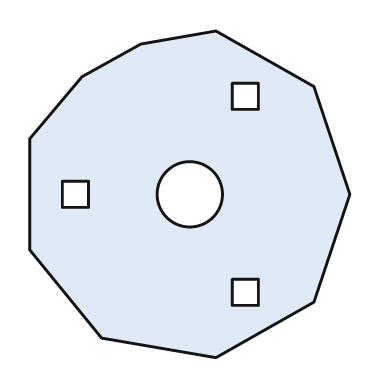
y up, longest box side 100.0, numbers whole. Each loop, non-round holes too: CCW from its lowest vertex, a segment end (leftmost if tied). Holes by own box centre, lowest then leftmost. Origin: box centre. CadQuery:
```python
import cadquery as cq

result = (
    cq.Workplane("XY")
    .moveTo(8.0, -50.0)
    .lineTo(38.0, -33.0)
    .lineTo(49.0, 0.0)
    .lineTo(38.0, 33.0)
    .lineTo(8.0, 50.0)
    .lineTo(-15.0, 46.0)
    .lineTo(-33.0, 36.0)
    .lineTo(-49.0, 17.0)
    .lineTo(-49.0, -17.0)
    .lineTo(-27.0, -44.0)
    .close()
    .moveTo(13.0, -34.0)
    .lineTo(21.0, -34.0)
    .lineTo(21.0, -26.0)
    .lineTo(13.0, -26.0)
    .close()
    .moveTo(-39.0, -4.0)
    .lineTo(-31.0, -4.0)
    .lineTo(-31.0, 4.0)
    .lineTo(-39.0, 4.0)
    .close()
    .moveTo(0.0, 0.0)
    .circle(10.0)
    .moveTo(13.0, 26.0)
    .lineTo(21.0, 26.0)
    .lineTo(21.0, 34.0)
    .lineTo(13.0, 34.0)
    .close()
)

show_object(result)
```